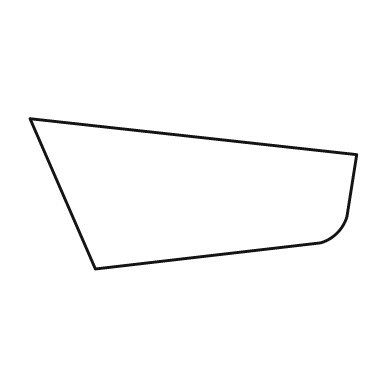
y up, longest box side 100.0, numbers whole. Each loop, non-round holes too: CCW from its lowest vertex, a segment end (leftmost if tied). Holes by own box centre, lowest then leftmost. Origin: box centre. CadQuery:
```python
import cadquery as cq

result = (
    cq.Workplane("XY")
    .moveTo(-30.0, -23.0)
    .lineTo(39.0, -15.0)
    .threePointArc((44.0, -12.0), (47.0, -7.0))
    .lineTo(50.0, 12.0)
    .lineTo(-50.0, 23.0)
    .close()
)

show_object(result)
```